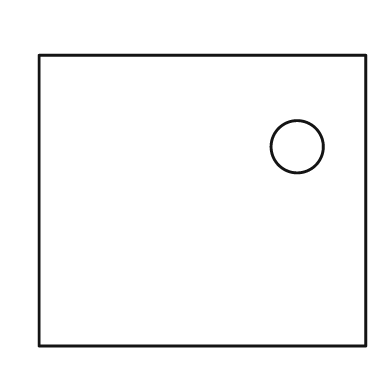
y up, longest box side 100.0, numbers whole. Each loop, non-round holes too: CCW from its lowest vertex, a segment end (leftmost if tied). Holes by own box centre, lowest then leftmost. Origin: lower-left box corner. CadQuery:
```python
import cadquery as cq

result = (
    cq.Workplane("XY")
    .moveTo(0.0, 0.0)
    .lineTo(100.0, 0.0)
    .lineTo(100.0, 89.0)
    .lineTo(0.0, 89.0)
    .close()
    .moveTo(79.0, 61.0)
    .circle(8.0)
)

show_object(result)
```